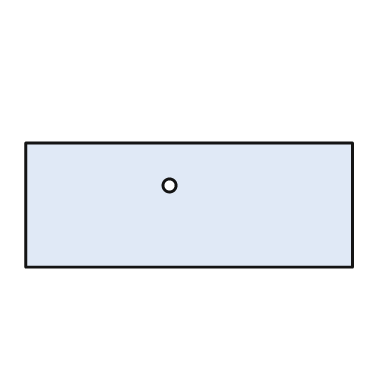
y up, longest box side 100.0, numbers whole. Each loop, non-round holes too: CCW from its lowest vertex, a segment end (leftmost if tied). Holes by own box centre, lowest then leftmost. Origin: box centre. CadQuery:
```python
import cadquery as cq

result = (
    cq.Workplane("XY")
    .moveTo(-50.0, -19.0)
    .lineTo(50.0, -19.0)
    .lineTo(50.0, 19.0)
    .lineTo(-50.0, 19.0)
    .close()
    .moveTo(-6.0, 6.0)
    .circle(2.0)
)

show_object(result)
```